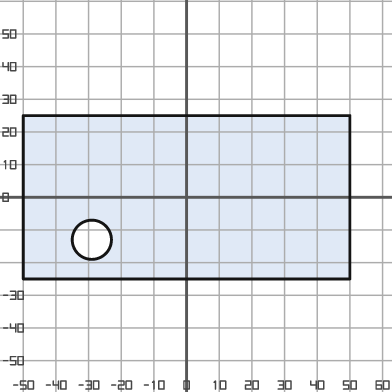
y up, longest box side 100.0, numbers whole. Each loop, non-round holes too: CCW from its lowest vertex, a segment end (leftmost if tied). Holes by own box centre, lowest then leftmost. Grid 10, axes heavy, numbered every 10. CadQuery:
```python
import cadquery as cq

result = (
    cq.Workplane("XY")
    .moveTo(-50.0, -25.0)
    .lineTo(50.0, -25.0)
    .lineTo(50.0, 25.0)
    .lineTo(-50.0, 25.0)
    .close()
    .moveTo(-29.0, -13.0)
    .circle(6.0)
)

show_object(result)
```